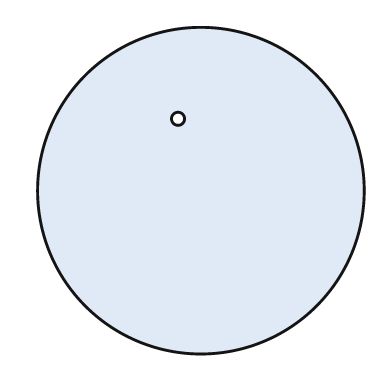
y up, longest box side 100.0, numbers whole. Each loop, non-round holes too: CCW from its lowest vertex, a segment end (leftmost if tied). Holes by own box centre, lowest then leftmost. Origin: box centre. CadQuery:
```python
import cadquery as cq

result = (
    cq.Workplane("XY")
    .moveTo(0.0, 0.0)
    .circle(50.0)
    .moveTo(-7.0, 22.0)
    .circle(2.0)
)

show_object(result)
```